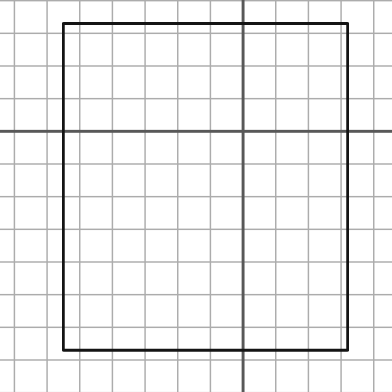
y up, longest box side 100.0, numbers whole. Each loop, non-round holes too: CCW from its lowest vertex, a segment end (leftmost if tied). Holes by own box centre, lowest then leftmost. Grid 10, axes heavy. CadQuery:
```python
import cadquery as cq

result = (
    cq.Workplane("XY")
    .moveTo(-55.0, -67.0)
    .lineTo(32.0, -67.0)
    .lineTo(32.0, 33.0)
    .lineTo(-55.0, 33.0)
    .close()
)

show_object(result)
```